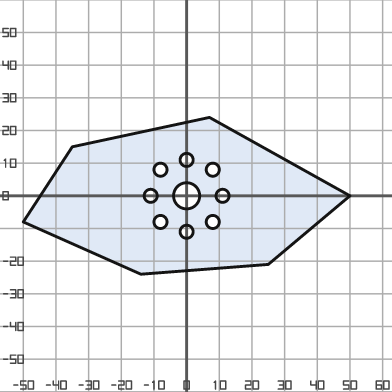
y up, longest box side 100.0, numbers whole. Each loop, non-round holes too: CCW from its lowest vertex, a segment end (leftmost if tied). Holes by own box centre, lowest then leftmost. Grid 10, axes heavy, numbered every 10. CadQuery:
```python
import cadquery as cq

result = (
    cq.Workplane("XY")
    .moveTo(-14.0, -24.0)
    .lineTo(25.0, -21.0)
    .lineTo(50.0, 0.0)
    .lineTo(7.0, 24.0)
    .lineTo(-35.0, 15.0)
    .lineTo(-50.0, -8.0)
    .close()
    .moveTo(0.0, -11.0)
    .circle(2.0)
    .moveTo(-8.0, -8.0)
    .circle(2.0)
    .moveTo(8.0, -8.0)
    .circle(2.0)
    .moveTo(-11.0, 0.0)
    .circle(2.0)
    .moveTo(0.0, 0.0)
    .circle(4.0)
    .moveTo(11.0, 0.0)
    .circle(2.0)
    .moveTo(-8.0, 8.0)
    .circle(2.0)
    .moveTo(8.0, 8.0)
    .circle(2.0)
    .moveTo(0.0, 11.0)
    .circle(2.0)
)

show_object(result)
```